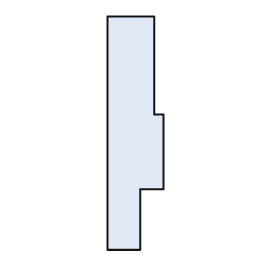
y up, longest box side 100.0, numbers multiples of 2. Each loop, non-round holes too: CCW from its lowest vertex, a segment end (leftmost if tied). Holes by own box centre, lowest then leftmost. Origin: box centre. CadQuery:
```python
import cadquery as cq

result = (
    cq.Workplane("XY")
    .moveTo(-12.0, -50.0)
    .lineTo(2.0, -50.0)
    .lineTo(2.0, -24.0)
    .lineTo(12.0, -24.0)
    .lineTo(12.0, 8.0)
    .lineTo(8.0, 8.0)
    .lineTo(8.0, 50.0)
    .lineTo(-12.0, 50.0)
    .close()
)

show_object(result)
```